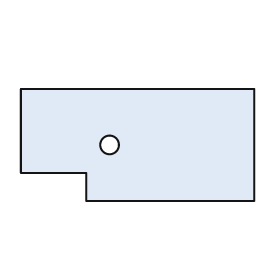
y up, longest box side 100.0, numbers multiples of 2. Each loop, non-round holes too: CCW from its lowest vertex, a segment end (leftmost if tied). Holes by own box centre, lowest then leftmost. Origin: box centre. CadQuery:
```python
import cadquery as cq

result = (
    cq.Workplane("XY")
    .moveTo(-22.0, -24.0)
    .lineTo(50.0, -24.0)
    .lineTo(50.0, 24.0)
    .lineTo(-50.0, 24.0)
    .lineTo(-50.0, -12.0)
    .lineTo(-22.0, -12.0)
    .close()
    .moveTo(-12.0, 0.0)
    .circle(4.0)
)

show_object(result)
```